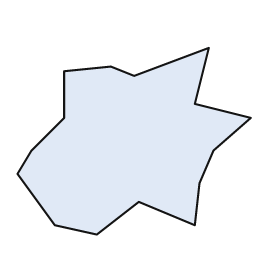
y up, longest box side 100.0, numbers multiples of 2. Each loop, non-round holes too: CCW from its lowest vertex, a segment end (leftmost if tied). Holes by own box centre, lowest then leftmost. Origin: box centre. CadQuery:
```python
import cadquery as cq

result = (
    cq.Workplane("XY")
    .moveTo(-16.0, -40.0)
    .lineTo(2.0, -26.0)
    .lineTo(26.0, -36.0)
    .lineTo(28.0, -18.0)
    .lineTo(34.0, -4.0)
    .lineTo(50.0, 10.0)
    .lineTo(26.0, 16.0)
    .lineTo(32.0, 40.0)
    .lineTo(0.0, 28.0)
    .lineTo(-10.0, 32.0)
    .lineTo(-30.0, 30.0)
    .lineTo(-30.0, 10.0)
    .lineTo(-44.0, -4.0)
    .lineTo(-50.0, -14.0)
    .lineTo(-34.0, -36.0)
    .close()
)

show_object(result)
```